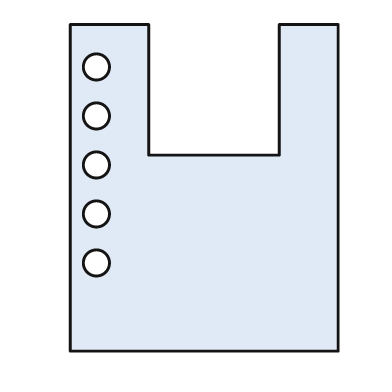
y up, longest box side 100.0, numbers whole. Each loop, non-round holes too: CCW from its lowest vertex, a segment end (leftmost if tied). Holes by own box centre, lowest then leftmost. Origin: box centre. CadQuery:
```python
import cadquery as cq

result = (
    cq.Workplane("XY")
    .moveTo(-41.0, -50.0)
    .lineTo(41.0, -50.0)
    .lineTo(41.0, 50.0)
    .lineTo(23.0, 50.0)
    .lineTo(23.0, 10.0)
    .lineTo(-17.0, 10.0)
    .lineTo(-17.0, 50.0)
    .lineTo(-41.0, 50.0)
    .close()
    .moveTo(-33.0, -23.0)
    .circle(4.0)
    .moveTo(-33.0, -8.0)
    .circle(4.0)
    .moveTo(-33.0, 7.0)
    .circle(4.0)
    .moveTo(-33.0, 22.0)
    .circle(4.0)
    .moveTo(-33.0, 37.0)
    .circle(4.0)
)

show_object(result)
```